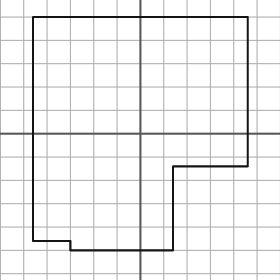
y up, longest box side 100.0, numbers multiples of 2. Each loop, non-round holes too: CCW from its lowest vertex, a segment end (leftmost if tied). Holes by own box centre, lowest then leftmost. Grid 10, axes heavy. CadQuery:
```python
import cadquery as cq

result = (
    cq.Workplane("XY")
    .moveTo(-30.0, -50.0)
    .lineTo(14.0, -50.0)
    .lineTo(14.0, -14.0)
    .lineTo(46.0, -14.0)
    .lineTo(46.0, 50.0)
    .lineTo(-46.0, 50.0)
    .lineTo(-46.0, -46.0)
    .lineTo(-30.0, -46.0)
    .close()
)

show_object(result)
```